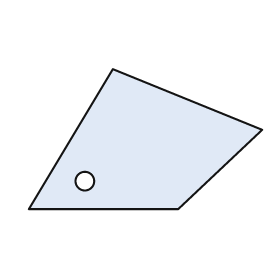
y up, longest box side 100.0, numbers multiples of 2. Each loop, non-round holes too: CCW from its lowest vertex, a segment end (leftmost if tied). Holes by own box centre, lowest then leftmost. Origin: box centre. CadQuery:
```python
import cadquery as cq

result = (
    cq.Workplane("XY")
    .moveTo(-50.0, -30.0)
    .lineTo(14.0, -30.0)
    .lineTo(50.0, 4.0)
    .lineTo(-14.0, 30.0)
    .close()
    .moveTo(-26.0, -18.0)
    .circle(4.0)
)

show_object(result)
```